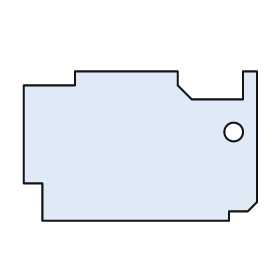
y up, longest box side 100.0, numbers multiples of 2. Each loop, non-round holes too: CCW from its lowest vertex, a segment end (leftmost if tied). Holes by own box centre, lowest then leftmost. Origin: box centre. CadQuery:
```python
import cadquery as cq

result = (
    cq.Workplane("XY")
    .moveTo(-42.0, -32.0)
    .lineTo(38.0, -32.0)
    .lineTo(38.0, -28.0)
    .lineTo(46.0, -28.0)
    .lineTo(50.0, -24.0)
    .lineTo(50.0, 32.0)
    .lineTo(44.0, 32.0)
    .lineTo(44.0, 20.0)
    .lineTo(22.0, 20.0)
    .lineTo(16.0, 26.0)
    .lineTo(16.0, 32.0)
    .lineTo(-28.0, 32.0)
    .lineTo(-28.0, 26.0)
    .lineTo(-50.0, 26.0)
    .lineTo(-50.0, -16.0)
    .lineTo(-42.0, -16.0)
    .close()
    .moveTo(40.0, 6.0)
    .circle(4.0)
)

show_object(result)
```